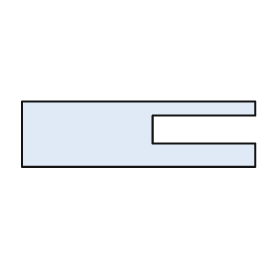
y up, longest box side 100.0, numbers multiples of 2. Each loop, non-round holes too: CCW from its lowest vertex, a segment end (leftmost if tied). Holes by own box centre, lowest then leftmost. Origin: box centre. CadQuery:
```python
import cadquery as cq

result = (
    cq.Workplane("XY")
    .moveTo(-50.0, -14.0)
    .lineTo(50.0, -14.0)
    .lineTo(50.0, -4.0)
    .lineTo(6.0, -4.0)
    .lineTo(6.0, 8.0)
    .lineTo(50.0, 8.0)
    .lineTo(50.0, 14.0)
    .lineTo(-50.0, 14.0)
    .close()
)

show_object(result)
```